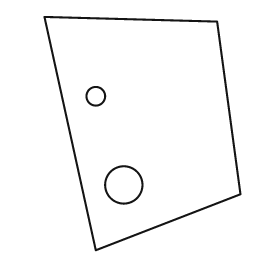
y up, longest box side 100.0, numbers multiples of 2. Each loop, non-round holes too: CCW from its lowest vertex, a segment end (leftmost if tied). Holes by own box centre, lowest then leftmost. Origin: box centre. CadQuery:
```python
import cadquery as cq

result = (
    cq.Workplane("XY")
    .moveTo(-20.0, -50.0)
    .lineTo(42.0, -26.0)
    .lineTo(32.0, 48.0)
    .lineTo(-42.0, 50.0)
    .close()
    .moveTo(-8.0, -22.0)
    .circle(8.0)
    .moveTo(-20.0, 16.0)
    .circle(4.0)
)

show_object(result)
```